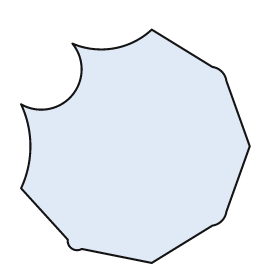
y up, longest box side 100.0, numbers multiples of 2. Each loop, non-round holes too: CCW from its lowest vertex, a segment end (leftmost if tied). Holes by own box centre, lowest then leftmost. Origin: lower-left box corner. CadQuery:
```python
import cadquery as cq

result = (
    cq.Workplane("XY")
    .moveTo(56.0, 0.0)
    .lineTo(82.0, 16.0)
    .threePointArc((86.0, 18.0), (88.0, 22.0))
    .lineTo(98.0, 50.0)
    .lineTo(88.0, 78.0)
    .threePointArc((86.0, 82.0), (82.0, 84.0))
    .lineTo(56.0, 100.0)
    .threePointArc((40.0, 92.0), (22.0, 94.0))
    .threePointArc((22.0, 72.0), (0.0, 68.0))
    .threePointArc((4.0, 50.0), (0.0, 32.0))
    .lineTo(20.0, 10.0)
    .threePointArc((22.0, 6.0), (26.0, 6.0))
    .close()
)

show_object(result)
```